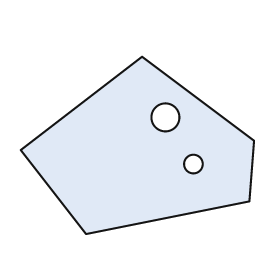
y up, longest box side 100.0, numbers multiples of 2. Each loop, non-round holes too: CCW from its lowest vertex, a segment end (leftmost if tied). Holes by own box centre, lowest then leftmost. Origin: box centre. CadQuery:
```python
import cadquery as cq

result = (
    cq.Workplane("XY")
    .moveTo(-22.0, -38.0)
    .lineTo(48.0, -24.0)
    .lineTo(50.0, 2.0)
    .lineTo(2.0, 38.0)
    .lineTo(-50.0, -2.0)
    .close()
    .moveTo(24.0, -8.0)
    .circle(4.0)
    .moveTo(12.0, 12.0)
    .circle(6.0)
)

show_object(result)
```